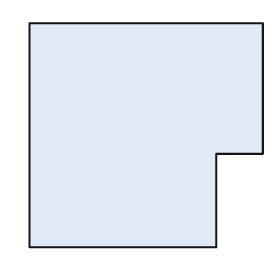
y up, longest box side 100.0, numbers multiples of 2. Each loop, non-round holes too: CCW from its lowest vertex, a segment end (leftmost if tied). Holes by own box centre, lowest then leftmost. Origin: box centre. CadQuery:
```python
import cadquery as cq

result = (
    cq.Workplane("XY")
    .moveTo(-50.0, -48.0)
    .lineTo(30.0, -48.0)
    .lineTo(30.0, -8.0)
    .lineTo(50.0, -8.0)
    .lineTo(50.0, 48.0)
    .lineTo(-50.0, 48.0)
    .close()
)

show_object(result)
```